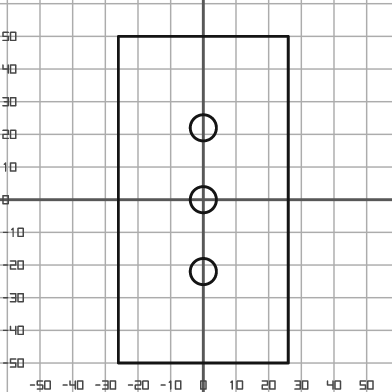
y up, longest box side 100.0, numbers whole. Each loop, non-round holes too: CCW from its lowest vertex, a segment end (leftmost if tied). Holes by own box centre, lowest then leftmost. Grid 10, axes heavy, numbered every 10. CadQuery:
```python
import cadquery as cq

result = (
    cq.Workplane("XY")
    .moveTo(-26.0, -50.0)
    .lineTo(26.0, -50.0)
    .lineTo(26.0, 50.0)
    .lineTo(-26.0, 50.0)
    .close()
    .moveTo(0.0, -22.0)
    .circle(4.0)
    .moveTo(0.0, 0.0)
    .circle(4.0)
    .moveTo(0.0, 22.0)
    .circle(4.0)
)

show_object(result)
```